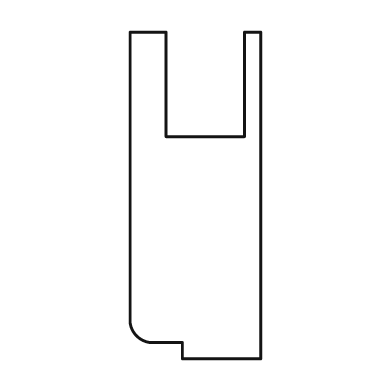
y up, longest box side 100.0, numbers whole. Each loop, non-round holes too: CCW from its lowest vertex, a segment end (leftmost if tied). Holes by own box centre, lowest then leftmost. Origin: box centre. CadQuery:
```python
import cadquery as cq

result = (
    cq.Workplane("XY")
    .moveTo(-4.0, -50.0)
    .lineTo(20.0, -50.0)
    .lineTo(20.0, 50.0)
    .lineTo(15.0, 50.0)
    .lineTo(15.0, 18.0)
    .lineTo(-9.0, 18.0)
    .lineTo(-9.0, 50.0)
    .lineTo(-20.0, 50.0)
    .lineTo(-20.0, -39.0)
    .threePointArc((-18.0, -43.0), (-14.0, -45.0))
    .lineTo(-4.0, -45.0)
    .close()
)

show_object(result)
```